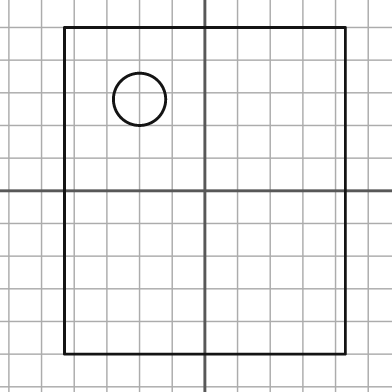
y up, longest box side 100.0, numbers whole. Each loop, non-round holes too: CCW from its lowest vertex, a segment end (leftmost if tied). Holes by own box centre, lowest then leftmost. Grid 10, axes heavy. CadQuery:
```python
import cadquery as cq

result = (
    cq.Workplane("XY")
    .moveTo(-43.0, -50.0)
    .lineTo(43.0, -50.0)
    .lineTo(43.0, 50.0)
    .lineTo(-43.0, 50.0)
    .close()
    .moveTo(-20.0, 28.0)
    .circle(8.0)
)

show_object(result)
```